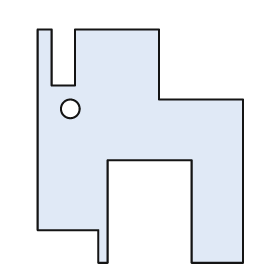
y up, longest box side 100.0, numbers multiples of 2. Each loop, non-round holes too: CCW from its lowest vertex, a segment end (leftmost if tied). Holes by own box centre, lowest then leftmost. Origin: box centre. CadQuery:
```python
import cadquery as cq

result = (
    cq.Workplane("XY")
    .moveTo(-18.0, -50.0)
    .lineTo(-14.0, -50.0)
    .lineTo(-14.0, -6.0)
    .lineTo(22.0, -6.0)
    .lineTo(22.0, -50.0)
    .lineTo(44.0, -50.0)
    .lineTo(44.0, 20.0)
    .lineTo(8.0, 20.0)
    .lineTo(8.0, 50.0)
    .lineTo(-28.0, 50.0)
    .lineTo(-28.0, 26.0)
    .lineTo(-38.0, 26.0)
    .lineTo(-38.0, 50.0)
    .lineTo(-44.0, 50.0)
    .lineTo(-44.0, -36.0)
    .lineTo(-18.0, -36.0)
    .close()
    .moveTo(-30.0, 16.0)
    .circle(4.0)
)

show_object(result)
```